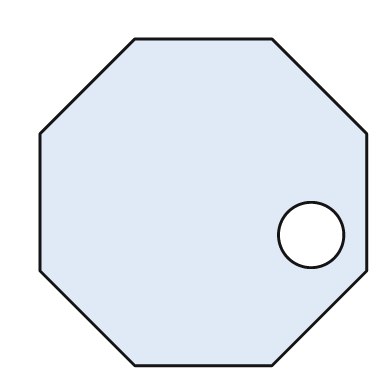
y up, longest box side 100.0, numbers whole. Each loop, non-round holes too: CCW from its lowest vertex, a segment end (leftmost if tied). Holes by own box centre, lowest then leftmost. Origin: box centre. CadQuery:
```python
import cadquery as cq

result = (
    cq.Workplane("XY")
    .moveTo(-21.0, -50.0)
    .lineTo(21.0, -50.0)
    .lineTo(50.0, -21.0)
    .lineTo(50.0, 21.0)
    .lineTo(21.0, 50.0)
    .lineTo(-21.0, 50.0)
    .lineTo(-50.0, 21.0)
    .lineTo(-50.0, -21.0)
    .close()
    .moveTo(33.0, -10.0)
    .circle(10.0)
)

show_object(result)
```